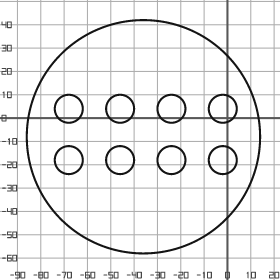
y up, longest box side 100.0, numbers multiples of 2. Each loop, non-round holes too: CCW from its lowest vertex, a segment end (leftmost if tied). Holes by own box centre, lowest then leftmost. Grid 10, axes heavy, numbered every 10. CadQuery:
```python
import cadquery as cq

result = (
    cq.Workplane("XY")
    .moveTo(-36.0, -8.0)
    .circle(50.0)
    .moveTo(-68.0, -18.0)
    .circle(6.0)
    .moveTo(-46.0, -18.0)
    .circle(6.0)
    .moveTo(-24.0, -18.0)
    .circle(6.0)
    .moveTo(-2.0, -18.0)
    .circle(6.0)
    .moveTo(-68.0, 4.0)
    .circle(6.0)
    .moveTo(-46.0, 4.0)
    .circle(6.0)
    .moveTo(-24.0, 4.0)
    .circle(6.0)
    .moveTo(-2.0, 4.0)
    .circle(6.0)
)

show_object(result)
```